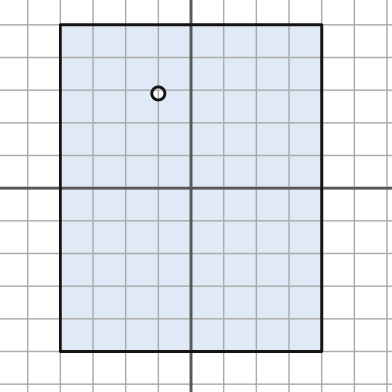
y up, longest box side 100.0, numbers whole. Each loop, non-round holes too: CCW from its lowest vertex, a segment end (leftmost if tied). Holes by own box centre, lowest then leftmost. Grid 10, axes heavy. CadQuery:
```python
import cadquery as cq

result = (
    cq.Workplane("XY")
    .moveTo(-40.0, -50.0)
    .lineTo(40.0, -50.0)
    .lineTo(40.0, 50.0)
    .lineTo(-40.0, 50.0)
    .close()
    .moveTo(-10.0, 29.0)
    .circle(2.0)
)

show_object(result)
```